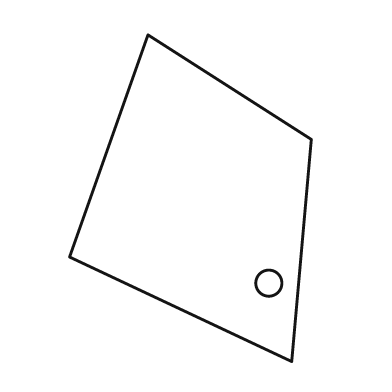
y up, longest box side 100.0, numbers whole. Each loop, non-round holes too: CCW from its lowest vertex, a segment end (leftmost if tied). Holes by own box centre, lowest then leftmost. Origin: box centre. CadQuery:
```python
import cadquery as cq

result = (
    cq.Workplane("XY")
    .moveTo(31.0, -50.0)
    .lineTo(37.0, 18.0)
    .lineTo(-13.0, 50.0)
    .lineTo(-37.0, -18.0)
    .close()
    .moveTo(24.0, -26.0)
    .circle(4.0)
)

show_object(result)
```